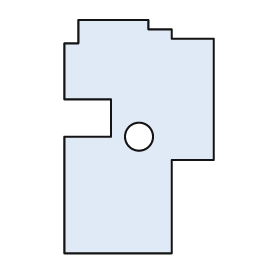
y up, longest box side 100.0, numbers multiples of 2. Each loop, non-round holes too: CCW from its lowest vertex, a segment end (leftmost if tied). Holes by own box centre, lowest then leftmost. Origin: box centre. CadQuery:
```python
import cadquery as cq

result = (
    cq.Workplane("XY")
    .moveTo(-32.0, -50.0)
    .lineTo(14.0, -50.0)
    .lineTo(14.0, -10.0)
    .lineTo(32.0, -10.0)
    .lineTo(32.0, 42.0)
    .lineTo(14.0, 42.0)
    .lineTo(14.0, 46.0)
    .lineTo(4.0, 46.0)
    .lineTo(4.0, 50.0)
    .lineTo(-26.0, 50.0)
    .lineTo(-26.0, 40.0)
    .lineTo(-32.0, 40.0)
    .lineTo(-32.0, 16.0)
    .lineTo(-12.0, 16.0)
    .lineTo(-12.0, 0.0)
    .lineTo(-32.0, 0.0)
    .close()
    .moveTo(0.0, 0.0)
    .circle(6.0)
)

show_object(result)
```